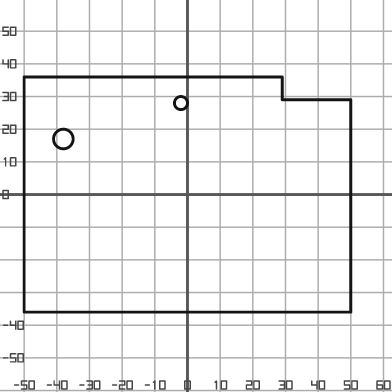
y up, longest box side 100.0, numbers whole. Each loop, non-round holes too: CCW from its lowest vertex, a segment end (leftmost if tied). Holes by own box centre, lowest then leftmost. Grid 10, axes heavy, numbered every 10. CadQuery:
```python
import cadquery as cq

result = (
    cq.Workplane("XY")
    .moveTo(-50.0, -36.0)
    .lineTo(50.0, -36.0)
    .lineTo(50.0, 29.0)
    .lineTo(29.0, 29.0)
    .lineTo(29.0, 36.0)
    .lineTo(-50.0, 36.0)
    .close()
    .moveTo(-38.0, 17.0)
    .circle(3.0)
    .moveTo(-2.0, 28.0)
    .circle(2.0)
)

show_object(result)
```